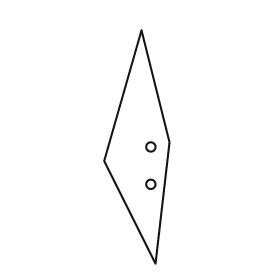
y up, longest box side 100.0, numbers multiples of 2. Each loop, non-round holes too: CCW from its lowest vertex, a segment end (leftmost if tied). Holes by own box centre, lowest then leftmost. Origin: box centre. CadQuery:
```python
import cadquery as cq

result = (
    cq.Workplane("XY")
    .moveTo(8.0, -50.0)
    .lineTo(14.0, 2.0)
    .lineTo(2.0, 50.0)
    .lineTo(-14.0, -6.0)
    .close()
    .moveTo(6.0, -16.0)
    .circle(2.0)
    .moveTo(6.0, 0.0)
    .circle(2.0)
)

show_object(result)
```